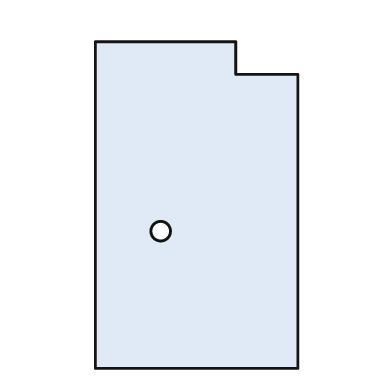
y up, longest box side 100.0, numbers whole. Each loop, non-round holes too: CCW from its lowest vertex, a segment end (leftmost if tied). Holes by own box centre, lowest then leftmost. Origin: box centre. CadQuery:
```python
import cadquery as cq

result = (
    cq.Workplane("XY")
    .moveTo(-31.0, -50.0)
    .lineTo(31.0, -50.0)
    .lineTo(31.0, 40.0)
    .lineTo(12.0, 40.0)
    .lineTo(12.0, 50.0)
    .lineTo(-31.0, 50.0)
    .close()
    .moveTo(-11.0, -8.0)
    .circle(3.0)
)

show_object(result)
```